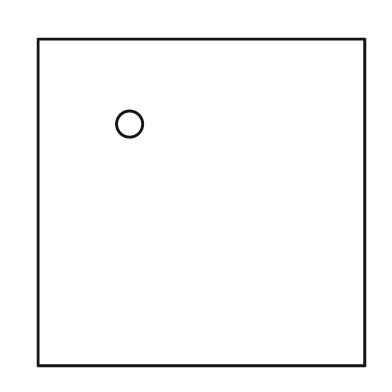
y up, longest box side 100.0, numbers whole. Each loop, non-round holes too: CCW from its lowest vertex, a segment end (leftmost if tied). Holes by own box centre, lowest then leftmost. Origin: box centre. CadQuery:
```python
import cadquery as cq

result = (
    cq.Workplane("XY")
    .moveTo(-50.0, -50.0)
    .lineTo(50.0, -50.0)
    .lineTo(50.0, 50.0)
    .lineTo(-50.0, 50.0)
    .close()
    .moveTo(-22.0, 24.0)
    .circle(4.0)
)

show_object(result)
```